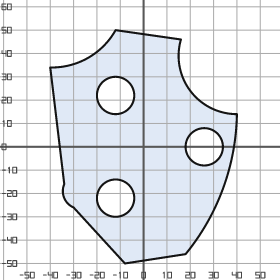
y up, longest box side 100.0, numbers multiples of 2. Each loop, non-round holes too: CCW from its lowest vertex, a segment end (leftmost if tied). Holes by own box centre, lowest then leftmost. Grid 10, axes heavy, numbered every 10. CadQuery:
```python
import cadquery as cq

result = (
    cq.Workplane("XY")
    .moveTo(-8.0, -50.0)
    .lineTo(18.0, -46.0)
    .threePointArc((34.0, -18.0), (40.0, 14.0))
    .threePointArc((20.0, 24.0), (16.0, 46.0))
    .lineTo(-12.0, 50.0)
    .threePointArc((-24.0, 38.0), (-40.0, 34.0))
    .lineTo(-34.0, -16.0)
    .threePointArc((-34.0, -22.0), (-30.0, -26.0))
    .close()
    .moveTo(-12.0, -22.0)
    .circle(8.0)
    .moveTo(26.0, 0.0)
    .circle(8.0)
    .moveTo(-12.0, 22.0)
    .circle(8.0)
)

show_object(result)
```